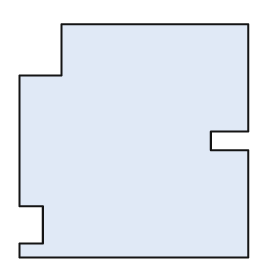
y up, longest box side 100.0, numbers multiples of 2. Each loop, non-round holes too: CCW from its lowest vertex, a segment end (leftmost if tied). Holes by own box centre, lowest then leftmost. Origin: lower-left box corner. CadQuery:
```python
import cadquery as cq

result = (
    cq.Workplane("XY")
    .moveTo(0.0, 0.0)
    .lineTo(98.0, 0.0)
    .lineTo(98.0, 46.0)
    .lineTo(82.0, 46.0)
    .lineTo(82.0, 54.0)
    .lineTo(98.0, 54.0)
    .lineTo(98.0, 100.0)
    .lineTo(18.0, 100.0)
    .lineTo(18.0, 78.0)
    .lineTo(0.0, 78.0)
    .lineTo(0.0, 22.0)
    .lineTo(10.0, 22.0)
    .lineTo(10.0, 6.0)
    .lineTo(0.0, 6.0)
    .close()
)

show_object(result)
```